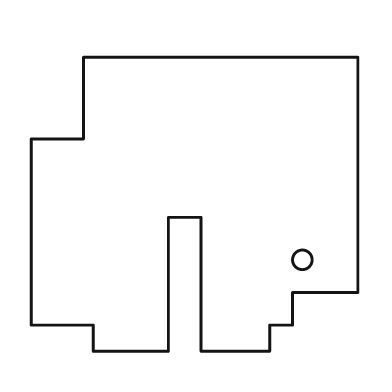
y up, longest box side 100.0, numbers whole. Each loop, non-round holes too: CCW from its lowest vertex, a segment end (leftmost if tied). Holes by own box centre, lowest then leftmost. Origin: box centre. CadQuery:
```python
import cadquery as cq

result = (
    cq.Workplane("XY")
    .moveTo(-31.0, -45.0)
    .lineTo(-8.0, -45.0)
    .lineTo(-8.0, -4.0)
    .lineTo(2.0, -4.0)
    .lineTo(2.0, -45.0)
    .lineTo(23.0, -45.0)
    .lineTo(23.0, -37.0)
    .lineTo(30.0, -37.0)
    .lineTo(30.0, -27.0)
    .lineTo(50.0, -27.0)
    .lineTo(50.0, 45.0)
    .lineTo(-34.0, 45.0)
    .lineTo(-34.0, 20.0)
    .lineTo(-50.0, 20.0)
    .lineTo(-50.0, -37.0)
    .lineTo(-31.0, -37.0)
    .close()
    .moveTo(33.0, -17.0)
    .circle(3.0)
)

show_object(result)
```